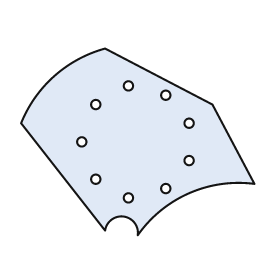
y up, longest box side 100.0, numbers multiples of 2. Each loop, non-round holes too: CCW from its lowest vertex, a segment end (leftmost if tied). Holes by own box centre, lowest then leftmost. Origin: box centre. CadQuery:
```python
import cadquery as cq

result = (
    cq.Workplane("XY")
    .moveTo(0.0, -40.0)
    .threePointArc((22.0, -22.0), (50.0, -18.0))
    .lineTo(32.0, 16.0)
    .lineTo(-14.0, 40.0)
    .threePointArc((-36.0, 28.0), (-50.0, 8.0))
    .lineTo(-14.0, -38.0)
    .threePointArc((-6.0, -32.0), (0.0, -40.0))
    .close()
    .moveTo(-4.0, -24.0)
    .circle(2.0)
    .moveTo(12.0, -20.0)
    .circle(2.0)
    .moveTo(-18.0, -16.0)
    .circle(2.0)
    .moveTo(22.0, -8.0)
    .circle(2.0)
    .moveTo(-24.0, 0.0)
    .circle(2.0)
    .moveTo(22.0, 8.0)
    .circle(2.0)
    .moveTo(-18.0, 16.0)
    .circle(2.0)
    .moveTo(12.0, 20.0)
    .circle(2.0)
    .moveTo(-4.0, 24.0)
    .circle(2.0)
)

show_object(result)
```